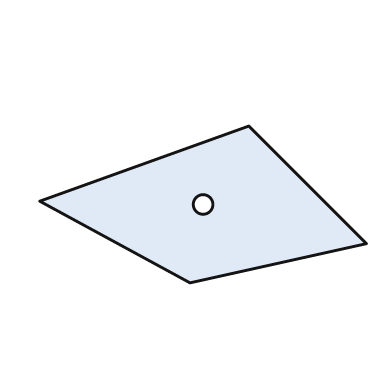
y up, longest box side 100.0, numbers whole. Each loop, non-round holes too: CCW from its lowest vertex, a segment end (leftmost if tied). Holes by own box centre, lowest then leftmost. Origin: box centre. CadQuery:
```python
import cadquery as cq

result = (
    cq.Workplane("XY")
    .moveTo(-4.0, -24.0)
    .lineTo(50.0, -12.0)
    .lineTo(14.0, 24.0)
    .lineTo(-50.0, 1.0)
    .close()
    .moveTo(0.0, 0.0)
    .circle(3.0)
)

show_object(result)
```